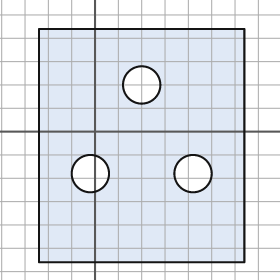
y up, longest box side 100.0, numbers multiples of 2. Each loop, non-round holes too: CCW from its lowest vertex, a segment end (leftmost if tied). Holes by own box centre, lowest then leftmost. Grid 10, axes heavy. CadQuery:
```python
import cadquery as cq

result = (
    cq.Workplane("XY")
    .moveTo(-24.0, -56.0)
    .lineTo(64.0, -56.0)
    .lineTo(64.0, 44.0)
    .lineTo(-24.0, 44.0)
    .close()
    .moveTo(-2.0, -18.0)
    .circle(8.0)
    .moveTo(42.0, -18.0)
    .circle(8.0)
    .moveTo(20.0, 20.0)
    .circle(8.0)
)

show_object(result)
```